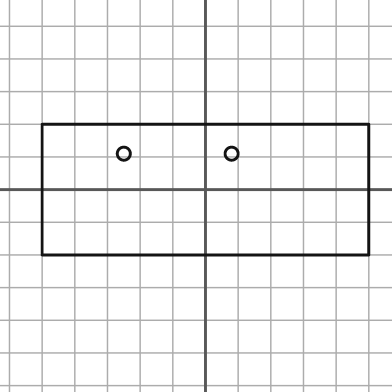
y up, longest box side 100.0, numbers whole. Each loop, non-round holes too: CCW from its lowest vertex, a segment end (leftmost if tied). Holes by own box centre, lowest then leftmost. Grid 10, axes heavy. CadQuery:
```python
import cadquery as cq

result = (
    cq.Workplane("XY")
    .moveTo(-50.0, -20.0)
    .lineTo(50.0, -20.0)
    .lineTo(50.0, 20.0)
    .lineTo(-50.0, 20.0)
    .close()
    .moveTo(-25.0, 11.0)
    .circle(2.0)
    .moveTo(8.0, 11.0)
    .circle(2.0)
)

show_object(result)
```